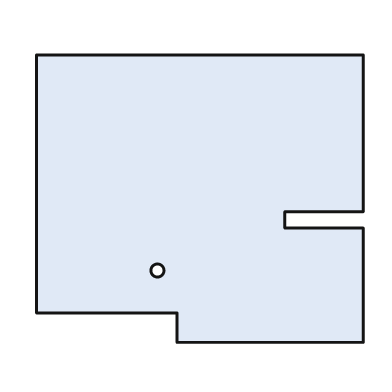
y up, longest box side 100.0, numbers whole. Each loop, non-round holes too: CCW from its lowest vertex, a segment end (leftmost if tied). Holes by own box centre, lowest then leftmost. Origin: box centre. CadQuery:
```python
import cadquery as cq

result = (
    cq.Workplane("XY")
    .moveTo(-7.0, -44.0)
    .lineTo(50.0, -44.0)
    .lineTo(50.0, -9.0)
    .lineTo(26.0, -9.0)
    .lineTo(26.0, -4.0)
    .lineTo(50.0, -4.0)
    .lineTo(50.0, 44.0)
    .lineTo(-50.0, 44.0)
    .lineTo(-50.0, -35.0)
    .lineTo(-7.0, -35.0)
    .close()
    .moveTo(-13.0, -22.0)
    .circle(2.0)
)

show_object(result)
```